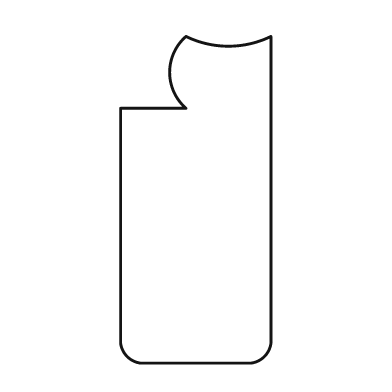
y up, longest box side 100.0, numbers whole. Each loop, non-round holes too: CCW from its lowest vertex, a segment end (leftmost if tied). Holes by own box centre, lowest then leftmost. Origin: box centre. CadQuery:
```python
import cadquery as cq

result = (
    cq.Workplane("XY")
    .moveTo(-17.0, -50.0)
    .lineTo(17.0, -50.0)
    .threePointArc((21.0, -48.0), (23.0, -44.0))
    .lineTo(23.0, 50.0)
    .threePointArc((10.0, 47.0), (-3.0, 50.0))
    .threePointArc((-8.0, 39.0), (-3.0, 28.0))
    .lineTo(-23.0, 28.0)
    .lineTo(-23.0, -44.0)
    .threePointArc((-21.0, -48.0), (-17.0, -50.0))
    .close()
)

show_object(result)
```